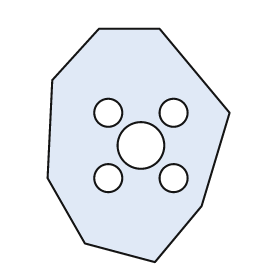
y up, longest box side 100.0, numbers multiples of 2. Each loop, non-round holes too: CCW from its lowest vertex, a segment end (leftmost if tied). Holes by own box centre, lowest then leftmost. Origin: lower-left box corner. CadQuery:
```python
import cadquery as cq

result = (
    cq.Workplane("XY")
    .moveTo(46.0, 0.0)
    .lineTo(66.0, 24.0)
    .lineTo(78.0, 64.0)
    .lineTo(48.0, 100.0)
    .lineTo(22.0, 100.0)
    .lineTo(2.0, 78.0)
    .lineTo(0.0, 36.0)
    .lineTo(16.0, 8.0)
    .close()
    .moveTo(26.0, 36.0)
    .circle(6.0)
    .moveTo(54.0, 36.0)
    .circle(6.0)
    .moveTo(40.0, 50.0)
    .circle(10.0)
    .moveTo(26.0, 64.0)
    .circle(6.0)
    .moveTo(54.0, 64.0)
    .circle(6.0)
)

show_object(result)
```